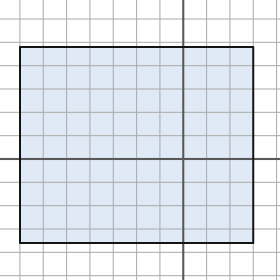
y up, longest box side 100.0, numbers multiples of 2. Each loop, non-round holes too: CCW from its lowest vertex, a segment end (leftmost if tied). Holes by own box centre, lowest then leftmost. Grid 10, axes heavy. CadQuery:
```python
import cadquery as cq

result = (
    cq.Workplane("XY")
    .moveTo(-70.0, -36.0)
    .lineTo(30.0, -36.0)
    .lineTo(30.0, 48.0)
    .lineTo(-70.0, 48.0)
    .close()
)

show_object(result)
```